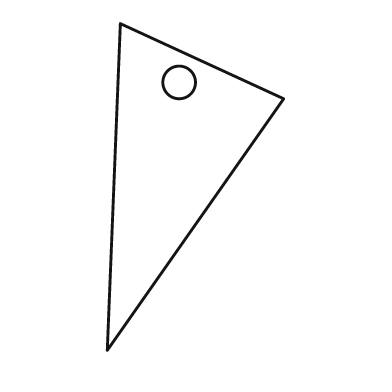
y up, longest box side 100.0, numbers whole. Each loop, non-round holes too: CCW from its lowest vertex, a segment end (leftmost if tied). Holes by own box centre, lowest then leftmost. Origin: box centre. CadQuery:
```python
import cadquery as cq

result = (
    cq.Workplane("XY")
    .moveTo(-27.0, -50.0)
    .lineTo(27.0, 27.0)
    .lineTo(-23.0, 50.0)
    .close()
    .moveTo(-5.0, 32.0)
    .circle(5.0)
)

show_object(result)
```